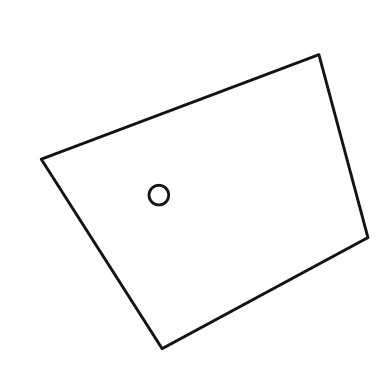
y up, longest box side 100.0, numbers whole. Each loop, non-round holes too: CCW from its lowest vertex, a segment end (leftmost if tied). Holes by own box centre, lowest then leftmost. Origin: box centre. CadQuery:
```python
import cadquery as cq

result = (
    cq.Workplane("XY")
    .moveTo(-13.0, -45.0)
    .lineTo(50.0, -11.0)
    .lineTo(35.0, 45.0)
    .lineTo(-50.0, 13.0)
    .close()
    .moveTo(-14.0, 2.0)
    .circle(3.0)
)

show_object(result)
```